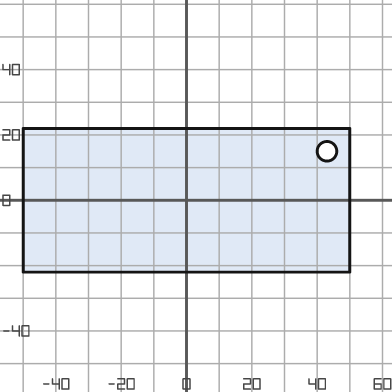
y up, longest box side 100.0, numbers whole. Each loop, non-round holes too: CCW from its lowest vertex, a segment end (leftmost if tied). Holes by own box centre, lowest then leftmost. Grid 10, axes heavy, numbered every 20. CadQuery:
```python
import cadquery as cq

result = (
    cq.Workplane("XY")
    .moveTo(-50.0, -22.0)
    .lineTo(50.0, -22.0)
    .lineTo(50.0, 22.0)
    .lineTo(-50.0, 22.0)
    .close()
    .moveTo(43.0, 15.0)
    .circle(3.0)
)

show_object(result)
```